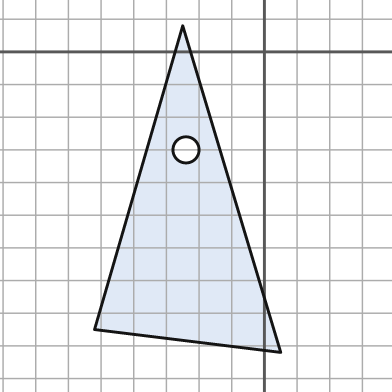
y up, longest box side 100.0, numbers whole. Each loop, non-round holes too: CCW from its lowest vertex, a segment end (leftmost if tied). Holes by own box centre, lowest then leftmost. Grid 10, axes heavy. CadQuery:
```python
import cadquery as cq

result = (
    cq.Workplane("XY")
    .moveTo(5.0, -92.0)
    .lineTo(-25.0, 8.0)
    .lineTo(-52.0, -85.0)
    .close()
    .moveTo(-24.0, -30.0)
    .circle(4.0)
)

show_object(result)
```